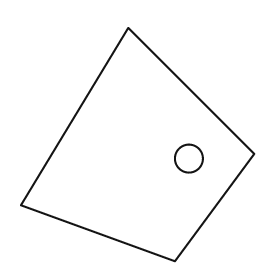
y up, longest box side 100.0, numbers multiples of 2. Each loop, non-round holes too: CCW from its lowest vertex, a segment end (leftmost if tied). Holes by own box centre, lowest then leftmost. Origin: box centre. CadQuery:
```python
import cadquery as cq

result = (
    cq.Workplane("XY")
    .moveTo(16.0, -50.0)
    .lineTo(50.0, -4.0)
    .lineTo(-4.0, 50.0)
    .lineTo(-50.0, -26.0)
    .close()
    .moveTo(22.0, -6.0)
    .circle(6.0)
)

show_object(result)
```